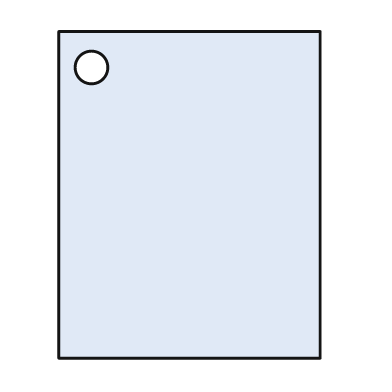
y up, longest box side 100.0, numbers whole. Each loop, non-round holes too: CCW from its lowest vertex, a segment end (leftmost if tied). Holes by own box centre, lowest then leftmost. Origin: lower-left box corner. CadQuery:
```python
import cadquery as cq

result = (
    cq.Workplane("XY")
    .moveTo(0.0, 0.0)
    .lineTo(80.0, 0.0)
    .lineTo(80.0, 100.0)
    .lineTo(0.0, 100.0)
    .close()
    .moveTo(10.0, 89.0)
    .circle(5.0)
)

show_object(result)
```